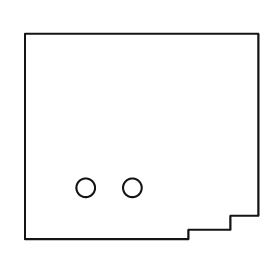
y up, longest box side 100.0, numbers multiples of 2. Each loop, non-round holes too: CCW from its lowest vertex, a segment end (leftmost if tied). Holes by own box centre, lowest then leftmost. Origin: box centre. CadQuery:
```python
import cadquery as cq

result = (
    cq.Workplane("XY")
    .moveTo(-50.0, -44.0)
    .lineTo(20.0, -44.0)
    .lineTo(20.0, -40.0)
    .lineTo(38.0, -40.0)
    .lineTo(38.0, -34.0)
    .lineTo(50.0, -34.0)
    .lineTo(50.0, 44.0)
    .lineTo(-50.0, 44.0)
    .close()
    .moveTo(-24.0, -22.0)
    .circle(4.0)
    .moveTo(-4.0, -22.0)
    .circle(4.0)
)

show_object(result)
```